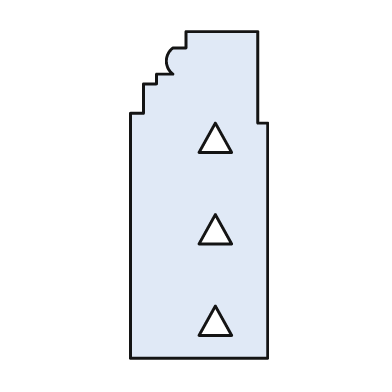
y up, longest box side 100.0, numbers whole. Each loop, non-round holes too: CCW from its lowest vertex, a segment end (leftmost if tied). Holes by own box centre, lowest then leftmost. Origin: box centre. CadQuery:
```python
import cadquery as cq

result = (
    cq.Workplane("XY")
    .moveTo(-21.0, -50.0)
    .lineTo(21.0, -50.0)
    .lineTo(21.0, 22.0)
    .lineTo(18.0, 22.0)
    .lineTo(18.0, 50.0)
    .lineTo(-4.0, 50.0)
    .lineTo(-4.0, 45.0)
    .lineTo(-8.0, 45.0)
    .threePointArc((-10.0, 41.0), (-8.0, 37.0))
    .lineTo(-13.0, 37.0)
    .lineTo(-13.0, 34.0)
    .lineTo(-17.0, 34.0)
    .lineTo(-17.0, 25.0)
    .lineTo(-21.0, 25.0)
    .close()
    .moveTo(0.0, -43.0)
    .lineTo(10.0, -43.0)
    .lineTo(5.0, -34.0)
    .close()
    .moveTo(0.0, -15.0)
    .lineTo(10.0, -15.0)
    .lineTo(5.0, -6.0)
    .close()
    .moveTo(0.0, 13.0)
    .lineTo(10.0, 13.0)
    .lineTo(5.0, 22.0)
    .close()
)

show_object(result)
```